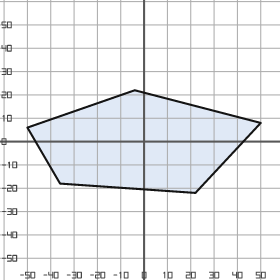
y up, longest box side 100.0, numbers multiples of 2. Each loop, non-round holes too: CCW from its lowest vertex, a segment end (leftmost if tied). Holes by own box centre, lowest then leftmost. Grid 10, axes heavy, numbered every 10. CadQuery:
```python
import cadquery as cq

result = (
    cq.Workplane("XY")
    .moveTo(22.0, -22.0)
    .lineTo(50.0, 8.0)
    .lineTo(-4.0, 22.0)
    .lineTo(-50.0, 6.0)
    .lineTo(-36.0, -18.0)
    .close()
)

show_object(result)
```